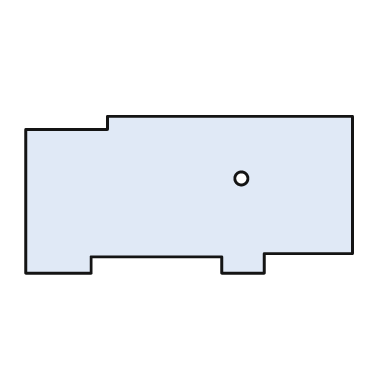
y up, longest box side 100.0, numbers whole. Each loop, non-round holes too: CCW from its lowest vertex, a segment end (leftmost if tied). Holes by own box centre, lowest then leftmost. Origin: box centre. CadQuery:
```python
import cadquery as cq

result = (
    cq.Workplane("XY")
    .moveTo(-50.0, -24.0)
    .lineTo(-30.0, -24.0)
    .lineTo(-30.0, -19.0)
    .lineTo(10.0, -19.0)
    .lineTo(10.0, -24.0)
    .lineTo(23.0, -24.0)
    .lineTo(23.0, -18.0)
    .lineTo(50.0, -18.0)
    .lineTo(50.0, 24.0)
    .lineTo(-25.0, 24.0)
    .lineTo(-25.0, 20.0)
    .lineTo(-50.0, 20.0)
    .close()
    .moveTo(16.0, 5.0)
    .circle(2.0)
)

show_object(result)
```